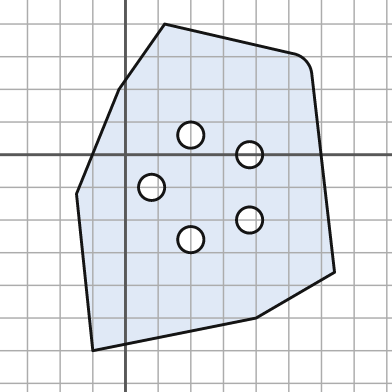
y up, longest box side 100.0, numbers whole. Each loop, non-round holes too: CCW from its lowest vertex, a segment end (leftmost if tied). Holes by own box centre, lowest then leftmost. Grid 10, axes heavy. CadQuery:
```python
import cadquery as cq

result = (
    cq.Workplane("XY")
    .moveTo(-10.0, -60.0)
    .lineTo(40.0, -50.0)
    .lineTo(64.0, -36.0)
    .lineTo(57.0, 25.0)
    .threePointArc((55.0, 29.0), (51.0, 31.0))
    .lineTo(12.0, 40.0)
    .lineTo(-2.0, 20.0)
    .lineTo(-15.0, -12.0)
    .close()
    .moveTo(20.0, -26.0)
    .circle(4.0)
    .moveTo(38.0, -20.0)
    .circle(4.0)
    .moveTo(8.0, -10.0)
    .circle(4.0)
    .moveTo(38.0, 0.0)
    .circle(4.0)
    .moveTo(20.0, 6.0)
    .circle(4.0)
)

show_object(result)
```